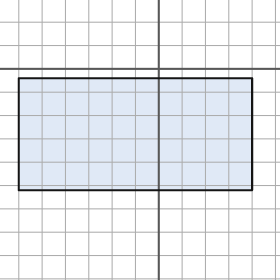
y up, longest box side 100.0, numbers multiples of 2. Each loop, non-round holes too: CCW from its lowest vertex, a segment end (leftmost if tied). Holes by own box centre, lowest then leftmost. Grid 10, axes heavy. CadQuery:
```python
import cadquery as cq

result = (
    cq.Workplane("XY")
    .moveTo(-60.0, -52.0)
    .lineTo(40.0, -52.0)
    .lineTo(40.0, -4.0)
    .lineTo(-60.0, -4.0)
    .close()
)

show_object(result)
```